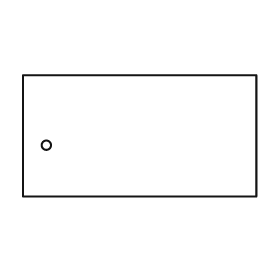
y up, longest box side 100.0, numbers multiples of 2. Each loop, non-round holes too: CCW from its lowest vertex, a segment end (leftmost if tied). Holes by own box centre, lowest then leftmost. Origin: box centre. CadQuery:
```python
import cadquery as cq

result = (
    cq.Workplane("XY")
    .moveTo(-50.0, -26.0)
    .lineTo(50.0, -26.0)
    .lineTo(50.0, 26.0)
    .lineTo(-50.0, 26.0)
    .close()
    .moveTo(-40.0, -4.0)
    .circle(2.0)
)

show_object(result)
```